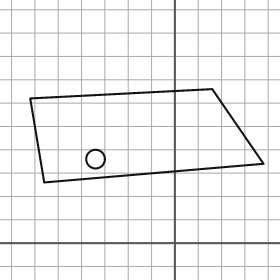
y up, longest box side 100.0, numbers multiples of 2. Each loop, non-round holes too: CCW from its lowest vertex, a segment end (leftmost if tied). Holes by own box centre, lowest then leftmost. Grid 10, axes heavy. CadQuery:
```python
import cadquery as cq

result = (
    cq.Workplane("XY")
    .moveTo(-56.0, 26.0)
    .lineTo(38.0, 34.0)
    .lineTo(16.0, 66.0)
    .lineTo(-62.0, 62.0)
    .close()
    .moveTo(-34.0, 36.0)
    .circle(4.0)
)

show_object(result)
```